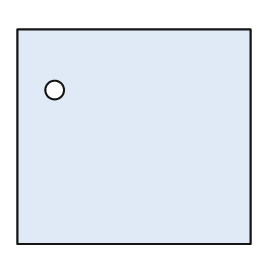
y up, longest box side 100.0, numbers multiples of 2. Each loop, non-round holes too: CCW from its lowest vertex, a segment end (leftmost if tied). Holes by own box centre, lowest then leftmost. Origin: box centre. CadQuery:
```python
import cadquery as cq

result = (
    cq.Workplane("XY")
    .moveTo(-50.0, -46.0)
    .lineTo(50.0, -46.0)
    .lineTo(50.0, 46.0)
    .lineTo(-50.0, 46.0)
    .close()
    .moveTo(-34.0, 20.0)
    .circle(4.0)
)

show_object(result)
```